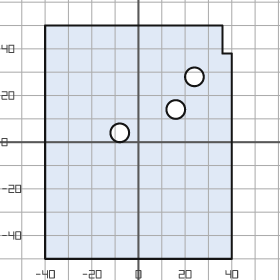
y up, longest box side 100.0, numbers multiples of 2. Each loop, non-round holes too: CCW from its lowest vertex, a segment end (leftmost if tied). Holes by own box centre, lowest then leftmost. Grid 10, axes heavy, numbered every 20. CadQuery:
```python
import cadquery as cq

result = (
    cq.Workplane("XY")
    .moveTo(-40.0, -50.0)
    .lineTo(40.0, -50.0)
    .lineTo(40.0, 38.0)
    .lineTo(36.0, 38.0)
    .lineTo(36.0, 50.0)
    .lineTo(-40.0, 50.0)
    .close()
    .moveTo(-8.0, 4.0)
    .circle(4.0)
    .moveTo(16.0, 14.0)
    .circle(4.0)
    .moveTo(24.0, 28.0)
    .circle(4.0)
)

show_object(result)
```